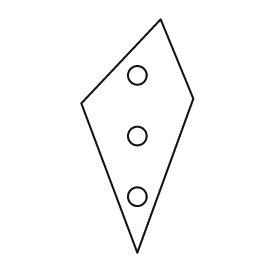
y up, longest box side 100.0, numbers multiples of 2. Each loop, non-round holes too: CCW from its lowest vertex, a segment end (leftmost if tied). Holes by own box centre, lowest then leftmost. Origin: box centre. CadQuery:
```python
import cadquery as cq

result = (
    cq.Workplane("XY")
    .moveTo(0.0, -50.0)
    .lineTo(24.0, 16.0)
    .lineTo(10.0, 50.0)
    .lineTo(-24.0, 14.0)
    .close()
    .moveTo(0.0, -26.0)
    .circle(4.0)
    .moveTo(0.0, 0.0)
    .circle(4.0)
    .moveTo(0.0, 26.0)
    .circle(4.0)
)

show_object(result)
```